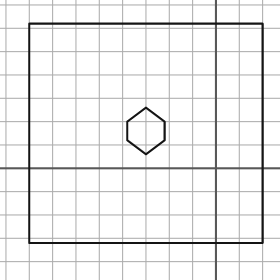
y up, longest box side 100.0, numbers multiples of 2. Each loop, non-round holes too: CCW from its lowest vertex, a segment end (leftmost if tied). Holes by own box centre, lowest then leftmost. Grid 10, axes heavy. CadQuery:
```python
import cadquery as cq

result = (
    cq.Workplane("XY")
    .moveTo(-80.0, -32.0)
    .lineTo(20.0, -32.0)
    .lineTo(20.0, 62.0)
    .lineTo(-80.0, 62.0)
    .close()
    .moveTo(-30.0, 6.0)
    .lineTo(-22.0, 12.0)
    .lineTo(-22.0, 20.0)
    .lineTo(-30.0, 26.0)
    .lineTo(-38.0, 20.0)
    .lineTo(-38.0, 12.0)
    .close()
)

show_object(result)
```